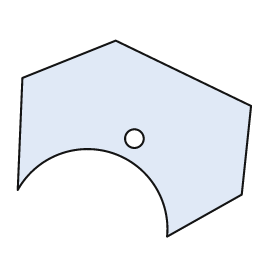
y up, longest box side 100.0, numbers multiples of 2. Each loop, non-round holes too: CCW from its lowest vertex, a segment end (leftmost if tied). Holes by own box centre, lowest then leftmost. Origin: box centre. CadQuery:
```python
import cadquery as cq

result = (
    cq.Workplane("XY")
    .moveTo(14.0, -42.0)
    .lineTo(46.0, -24.0)
    .lineTo(50.0, 14.0)
    .lineTo(-8.0, 42.0)
    .lineTo(-48.0, 26.0)
    .lineTo(-50.0, -22.0)
    .threePointArc((-10.0, -6.0), (14.0, -42.0))
    .close()
    .moveTo(0.0, 0.0)
    .circle(4.0)
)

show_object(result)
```